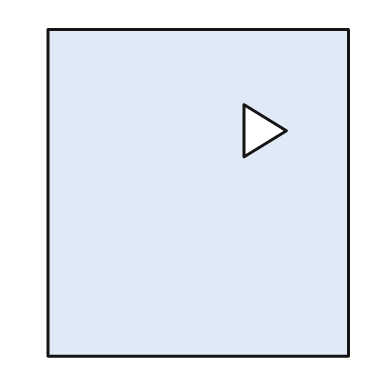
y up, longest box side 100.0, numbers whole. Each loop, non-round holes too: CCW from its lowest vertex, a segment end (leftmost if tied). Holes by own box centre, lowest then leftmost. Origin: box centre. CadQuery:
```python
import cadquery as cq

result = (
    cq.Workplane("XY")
    .moveTo(-46.0, -50.0)
    .lineTo(46.0, -50.0)
    .lineTo(46.0, 50.0)
    .lineTo(-46.0, 50.0)
    .close()
    .moveTo(14.0, 11.0)
    .lineTo(27.0, 19.0)
    .lineTo(14.0, 27.0)
    .close()
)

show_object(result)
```